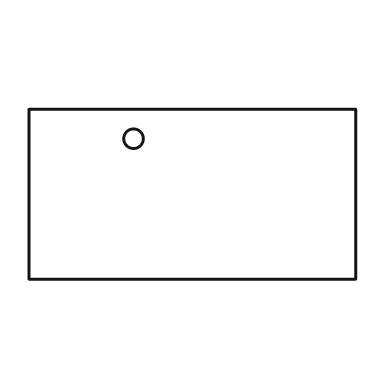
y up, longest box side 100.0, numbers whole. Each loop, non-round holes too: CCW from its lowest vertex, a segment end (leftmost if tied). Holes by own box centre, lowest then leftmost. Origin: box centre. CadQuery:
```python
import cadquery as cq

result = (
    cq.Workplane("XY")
    .moveTo(-50.0, -26.0)
    .lineTo(50.0, -26.0)
    .lineTo(50.0, 26.0)
    .lineTo(-50.0, 26.0)
    .close()
    .moveTo(-18.0, 17.0)
    .circle(3.0)
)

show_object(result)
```